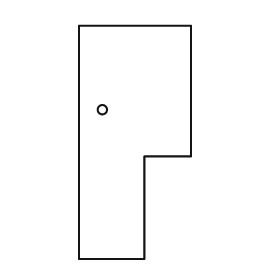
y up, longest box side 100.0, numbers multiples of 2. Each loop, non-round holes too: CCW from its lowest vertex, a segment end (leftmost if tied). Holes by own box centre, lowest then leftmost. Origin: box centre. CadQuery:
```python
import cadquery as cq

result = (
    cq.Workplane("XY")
    .moveTo(-24.0, -50.0)
    .lineTo(4.0, -50.0)
    .lineTo(4.0, -6.0)
    .lineTo(24.0, -6.0)
    .lineTo(24.0, 50.0)
    .lineTo(-24.0, 50.0)
    .close()
    .moveTo(-14.0, 14.0)
    .circle(2.0)
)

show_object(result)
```